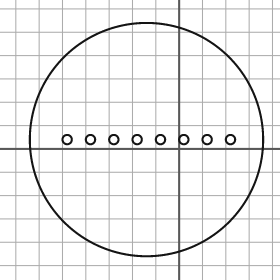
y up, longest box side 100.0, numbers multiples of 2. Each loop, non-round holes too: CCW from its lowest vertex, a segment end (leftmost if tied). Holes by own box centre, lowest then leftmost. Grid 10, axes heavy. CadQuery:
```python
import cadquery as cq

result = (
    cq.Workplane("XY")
    .moveTo(-14.0, 4.0)
    .circle(50.0)
    .moveTo(-48.0, 4.0)
    .circle(2.0)
    .moveTo(-38.0, 4.0)
    .circle(2.0)
    .moveTo(-28.0, 4.0)
    .circle(2.0)
    .moveTo(-18.0, 4.0)
    .circle(2.0)
    .moveTo(-8.0, 4.0)
    .circle(2.0)
    .moveTo(2.0, 4.0)
    .circle(2.0)
    .moveTo(12.0, 4.0)
    .circle(2.0)
    .moveTo(22.0, 4.0)
    .circle(2.0)
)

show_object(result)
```